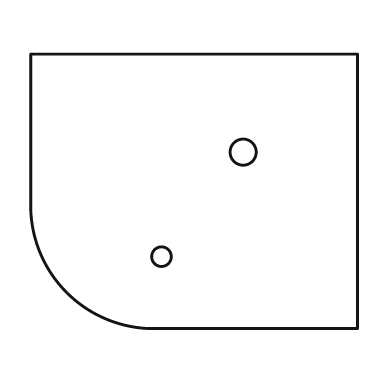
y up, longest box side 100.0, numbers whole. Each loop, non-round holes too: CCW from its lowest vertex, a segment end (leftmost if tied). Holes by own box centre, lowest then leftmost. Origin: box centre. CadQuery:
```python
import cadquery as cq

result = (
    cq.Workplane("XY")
    .moveTo(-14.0, -42.0)
    .lineTo(50.0, -42.0)
    .lineTo(50.0, 42.0)
    .lineTo(-50.0, 42.0)
    .lineTo(-50.0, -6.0)
    .threePointArc((-39.0, -31.0), (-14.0, -42.0))
    .close()
    .moveTo(-10.0, -20.0)
    .circle(3.0)
    .moveTo(15.0, 12.0)
    .circle(4.0)
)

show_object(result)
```